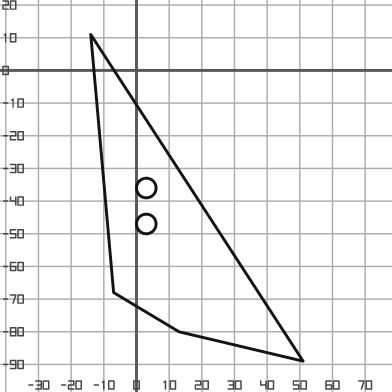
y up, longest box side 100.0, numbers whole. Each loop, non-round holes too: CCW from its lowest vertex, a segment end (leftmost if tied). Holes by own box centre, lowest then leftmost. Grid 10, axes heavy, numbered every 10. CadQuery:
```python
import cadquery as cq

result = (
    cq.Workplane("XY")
    .moveTo(51.0, -89.0)
    .lineTo(-14.0, 11.0)
    .lineTo(-7.0, -68.0)
    .lineTo(13.0, -80.0)
    .close()
    .moveTo(3.0, -47.0)
    .circle(3.0)
    .moveTo(3.0, -36.0)
    .circle(3.0)
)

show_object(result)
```